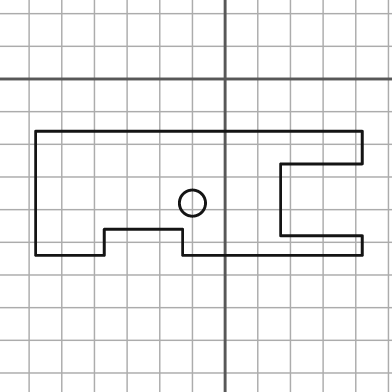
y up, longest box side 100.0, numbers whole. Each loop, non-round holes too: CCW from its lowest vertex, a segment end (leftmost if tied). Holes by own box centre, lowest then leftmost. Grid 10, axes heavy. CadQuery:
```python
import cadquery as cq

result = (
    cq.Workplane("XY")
    .moveTo(-58.0, -54.0)
    .lineTo(-37.0, -54.0)
    .lineTo(-37.0, -46.0)
    .lineTo(-13.0, -46.0)
    .lineTo(-13.0, -54.0)
    .lineTo(42.0, -54.0)
    .lineTo(42.0, -48.0)
    .lineTo(17.0, -48.0)
    .lineTo(17.0, -26.0)
    .lineTo(42.0, -26.0)
    .lineTo(42.0, -16.0)
    .lineTo(-58.0, -16.0)
    .close()
    .moveTo(-10.0, -38.0)
    .circle(4.0)
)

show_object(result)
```